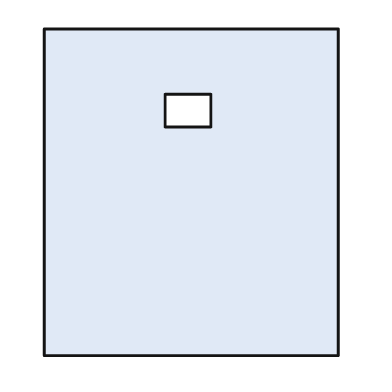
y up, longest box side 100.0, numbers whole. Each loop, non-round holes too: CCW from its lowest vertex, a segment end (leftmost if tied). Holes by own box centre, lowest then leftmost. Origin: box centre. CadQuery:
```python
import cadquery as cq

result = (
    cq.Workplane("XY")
    .moveTo(-45.0, -50.0)
    .lineTo(45.0, -50.0)
    .lineTo(45.0, 50.0)
    .lineTo(-45.0, 50.0)
    .close()
    .moveTo(-8.0, 20.0)
    .lineTo(6.0, 20.0)
    .lineTo(6.0, 30.0)
    .lineTo(-8.0, 30.0)
    .close()
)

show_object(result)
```